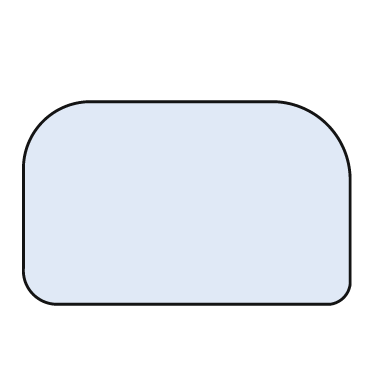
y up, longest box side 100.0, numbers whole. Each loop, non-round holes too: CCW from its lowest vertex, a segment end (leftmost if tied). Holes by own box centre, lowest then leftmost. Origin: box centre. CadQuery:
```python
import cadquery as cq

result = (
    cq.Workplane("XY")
    .moveTo(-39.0, -31.0)
    .lineTo(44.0, -31.0)
    .threePointArc((48.0, -29.0), (50.0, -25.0))
    .lineTo(50.0, 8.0)
    .threePointArc((43.0, 24.0), (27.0, 31.0))
    .lineTo(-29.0, 31.0)
    .threePointArc((-44.0, 25.0), (-50.0, 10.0))
    .lineTo(-50.0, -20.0)
    .threePointArc((-47.0, -28.0), (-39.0, -31.0))
    .close()
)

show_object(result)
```